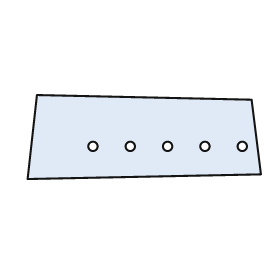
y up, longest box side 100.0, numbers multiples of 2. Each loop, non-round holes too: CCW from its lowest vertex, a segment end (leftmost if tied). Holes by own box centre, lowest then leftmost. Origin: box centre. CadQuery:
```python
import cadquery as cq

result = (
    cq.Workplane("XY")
    .moveTo(-50.0, -18.0)
    .lineTo(50.0, -16.0)
    .lineTo(46.0, 16.0)
    .lineTo(-46.0, 18.0)
    .close()
    .moveTo(-22.0, -4.0)
    .circle(2.0)
    .moveTo(-6.0, -4.0)
    .circle(2.0)
    .moveTo(10.0, -4.0)
    .circle(2.0)
    .moveTo(26.0, -4.0)
    .circle(2.0)
    .moveTo(42.0, -4.0)
    .circle(2.0)
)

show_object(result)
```